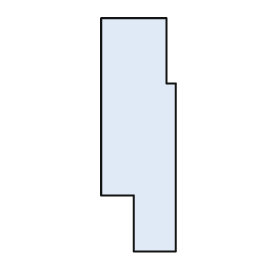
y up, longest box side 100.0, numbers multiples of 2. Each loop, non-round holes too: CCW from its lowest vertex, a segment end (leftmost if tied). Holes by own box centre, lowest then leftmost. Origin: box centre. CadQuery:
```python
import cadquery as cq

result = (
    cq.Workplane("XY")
    .moveTo(-2.0, -50.0)
    .lineTo(16.0, -50.0)
    .lineTo(16.0, 22.0)
    .lineTo(12.0, 22.0)
    .lineTo(12.0, 50.0)
    .lineTo(-16.0, 50.0)
    .lineTo(-16.0, -26.0)
    .lineTo(-2.0, -26.0)
    .close()
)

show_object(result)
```